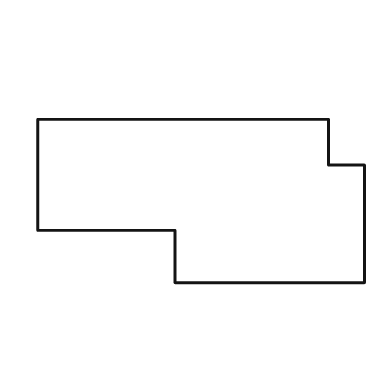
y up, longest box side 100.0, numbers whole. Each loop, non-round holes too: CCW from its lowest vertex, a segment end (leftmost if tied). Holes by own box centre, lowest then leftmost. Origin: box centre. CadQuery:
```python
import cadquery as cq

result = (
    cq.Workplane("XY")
    .moveTo(-8.0, -25.0)
    .lineTo(50.0, -25.0)
    .lineTo(50.0, 11.0)
    .lineTo(39.0, 11.0)
    .lineTo(39.0, 25.0)
    .lineTo(-50.0, 25.0)
    .lineTo(-50.0, -9.0)
    .lineTo(-8.0, -9.0)
    .close()
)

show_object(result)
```